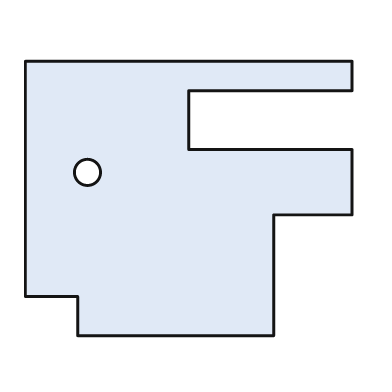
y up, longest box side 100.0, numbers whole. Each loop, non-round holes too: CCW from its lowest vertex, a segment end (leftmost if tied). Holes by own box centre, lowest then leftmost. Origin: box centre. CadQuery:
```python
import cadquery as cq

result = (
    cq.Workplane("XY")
    .moveTo(-34.0, -42.0)
    .lineTo(26.0, -42.0)
    .lineTo(26.0, -5.0)
    .lineTo(50.0, -5.0)
    .lineTo(50.0, 15.0)
    .lineTo(0.0, 15.0)
    .lineTo(0.0, 33.0)
    .lineTo(50.0, 33.0)
    .lineTo(50.0, 42.0)
    .lineTo(-50.0, 42.0)
    .lineTo(-50.0, -30.0)
    .lineTo(-34.0, -30.0)
    .close()
    .moveTo(-31.0, 8.0)
    .circle(4.0)
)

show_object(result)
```